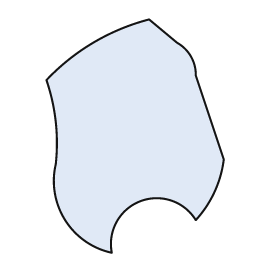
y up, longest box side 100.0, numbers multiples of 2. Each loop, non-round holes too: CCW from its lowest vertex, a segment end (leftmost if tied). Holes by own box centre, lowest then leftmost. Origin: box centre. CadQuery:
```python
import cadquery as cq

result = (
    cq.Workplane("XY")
    .moveTo(-10.0, -50.0)
    .threePointArc((2.0, -28.0), (26.0, -36.0))
    .threePointArc((34.0, -24.0), (38.0, -10.0))
    .lineTo(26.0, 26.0)
    .threePointArc((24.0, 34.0), (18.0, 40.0))
    .lineTo(6.0, 50.0)
    .threePointArc((-18.0, 40.0), (-38.0, 24.0))
    .threePointArc((-34.0, 6.0), (-34.0, -12.0))
    .threePointArc((-30.0, -36.0), (-10.0, -50.0))
    .close()
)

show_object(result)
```